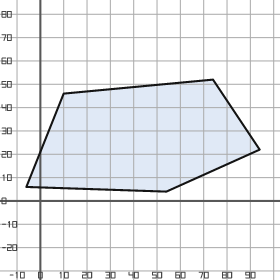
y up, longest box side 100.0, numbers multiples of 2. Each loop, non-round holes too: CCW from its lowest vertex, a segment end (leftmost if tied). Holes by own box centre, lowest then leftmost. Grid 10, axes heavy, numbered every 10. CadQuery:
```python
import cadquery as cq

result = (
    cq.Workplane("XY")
    .moveTo(54.0, 4.0)
    .lineTo(94.0, 22.0)
    .lineTo(74.0, 52.0)
    .lineTo(10.0, 46.0)
    .lineTo(-6.0, 6.0)
    .close()
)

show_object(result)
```